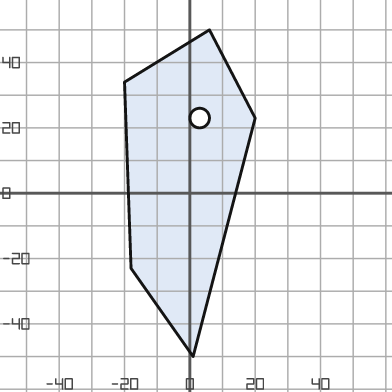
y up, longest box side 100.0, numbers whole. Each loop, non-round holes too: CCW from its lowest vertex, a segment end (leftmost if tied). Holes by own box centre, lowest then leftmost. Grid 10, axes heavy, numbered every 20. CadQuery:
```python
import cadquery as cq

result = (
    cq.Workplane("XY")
    .moveTo(1.0, -50.0)
    .lineTo(20.0, 23.0)
    .lineTo(6.0, 50.0)
    .lineTo(-20.0, 34.0)
    .lineTo(-18.0, -23.0)
    .close()
    .moveTo(3.0, 23.0)
    .circle(3.0)
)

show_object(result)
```